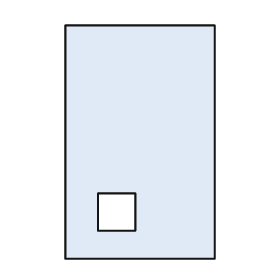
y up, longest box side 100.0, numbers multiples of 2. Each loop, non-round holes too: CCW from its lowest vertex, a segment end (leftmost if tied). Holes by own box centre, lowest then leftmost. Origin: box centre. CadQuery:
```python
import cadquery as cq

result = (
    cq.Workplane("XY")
    .moveTo(-32.0, -50.0)
    .lineTo(32.0, -50.0)
    .lineTo(32.0, 50.0)
    .lineTo(-32.0, 50.0)
    .close()
    .moveTo(-18.0, -38.0)
    .lineTo(-2.0, -38.0)
    .lineTo(-2.0, -22.0)
    .lineTo(-18.0, -22.0)
    .close()
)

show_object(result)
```